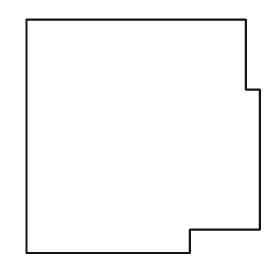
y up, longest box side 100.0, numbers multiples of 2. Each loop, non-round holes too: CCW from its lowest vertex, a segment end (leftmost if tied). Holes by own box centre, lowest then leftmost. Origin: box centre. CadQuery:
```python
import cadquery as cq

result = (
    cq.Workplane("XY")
    .moveTo(-50.0, -50.0)
    .lineTo(20.0, -50.0)
    .lineTo(20.0, -40.0)
    .lineTo(50.0, -40.0)
    .lineTo(50.0, 20.0)
    .lineTo(44.0, 20.0)
    .lineTo(44.0, 50.0)
    .lineTo(-50.0, 50.0)
    .close()
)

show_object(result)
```